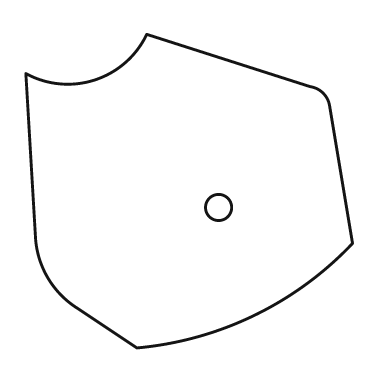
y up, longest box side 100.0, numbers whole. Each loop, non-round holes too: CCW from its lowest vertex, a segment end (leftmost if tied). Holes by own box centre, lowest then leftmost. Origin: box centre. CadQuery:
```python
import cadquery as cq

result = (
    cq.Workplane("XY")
    .moveTo(-16.0, -48.0)
    .threePointArc((20.0, -38.0), (50.0, -16.0))
    .lineTo(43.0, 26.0)
    .threePointArc((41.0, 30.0), (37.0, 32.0))
    .lineTo(-13.0, 48.0)
    .threePointArc((-29.0, 34.0), (-50.0, 36.0))
    .lineTo(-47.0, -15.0)
    .threePointArc((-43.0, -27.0), (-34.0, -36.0))
    .close()
    .moveTo(9.0, -5.0)
    .circle(4.0)
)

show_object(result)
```